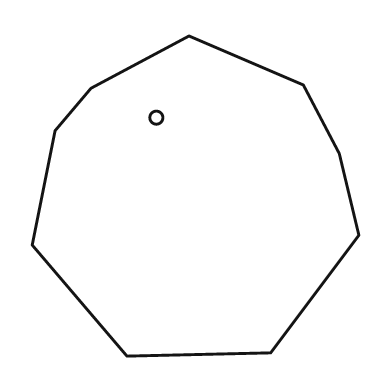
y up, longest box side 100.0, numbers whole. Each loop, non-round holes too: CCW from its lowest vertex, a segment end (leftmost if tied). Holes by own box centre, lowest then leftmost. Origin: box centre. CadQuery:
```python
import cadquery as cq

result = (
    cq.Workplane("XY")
    .moveTo(-21.0, -49.0)
    .lineTo(23.0, -48.0)
    .lineTo(50.0, -12.0)
    .lineTo(44.0, 13.0)
    .lineTo(33.0, 34.0)
    .lineTo(-2.0, 49.0)
    .lineTo(-32.0, 33.0)
    .lineTo(-43.0, 20.0)
    .lineTo(-50.0, -15.0)
    .close()
    .moveTo(-12.0, 24.0)
    .circle(2.0)
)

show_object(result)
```